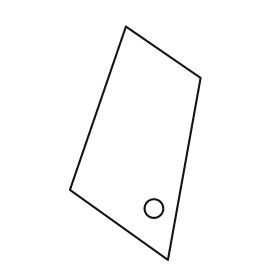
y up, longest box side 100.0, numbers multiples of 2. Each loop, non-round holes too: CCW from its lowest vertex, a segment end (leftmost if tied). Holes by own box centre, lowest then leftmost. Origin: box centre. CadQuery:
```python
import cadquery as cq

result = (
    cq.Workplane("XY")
    .moveTo(14.0, -50.0)
    .lineTo(28.0, 28.0)
    .lineTo(-4.0, 50.0)
    .lineTo(-28.0, -20.0)
    .close()
    .moveTo(8.0, -28.0)
    .circle(4.0)
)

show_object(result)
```